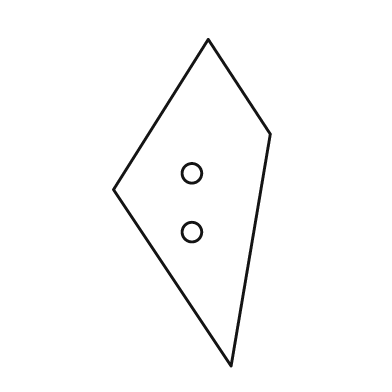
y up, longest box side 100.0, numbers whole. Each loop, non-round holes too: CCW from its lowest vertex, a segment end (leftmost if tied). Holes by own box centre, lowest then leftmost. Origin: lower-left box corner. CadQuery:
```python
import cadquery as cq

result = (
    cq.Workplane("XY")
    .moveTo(36.0, 0.0)
    .lineTo(48.0, 71.0)
    .lineTo(29.0, 100.0)
    .lineTo(0.0, 54.0)
    .close()
    .moveTo(24.0, 41.0)
    .circle(3.0)
    .moveTo(24.0, 59.0)
    .circle(3.0)
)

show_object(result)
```